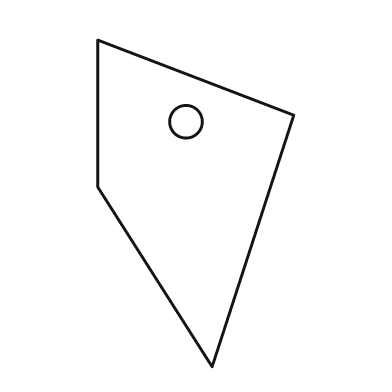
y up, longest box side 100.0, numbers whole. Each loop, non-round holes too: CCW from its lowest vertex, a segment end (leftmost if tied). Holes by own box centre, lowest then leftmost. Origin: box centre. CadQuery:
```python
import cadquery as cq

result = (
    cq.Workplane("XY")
    .moveTo(5.0, -50.0)
    .lineTo(30.0, 27.0)
    .lineTo(-30.0, 50.0)
    .lineTo(-30.0, 5.0)
    .close()
    .moveTo(-3.0, 25.0)
    .circle(5.0)
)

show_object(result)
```